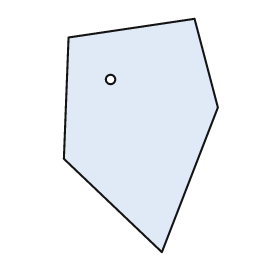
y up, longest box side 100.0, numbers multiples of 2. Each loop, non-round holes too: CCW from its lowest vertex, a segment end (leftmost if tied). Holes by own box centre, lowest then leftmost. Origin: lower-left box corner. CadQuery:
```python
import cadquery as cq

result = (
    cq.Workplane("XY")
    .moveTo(42.0, 0.0)
    .lineTo(66.0, 62.0)
    .lineTo(56.0, 100.0)
    .lineTo(2.0, 92.0)
    .lineTo(0.0, 40.0)
    .close()
    .moveTo(20.0, 74.0)
    .circle(2.0)
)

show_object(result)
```